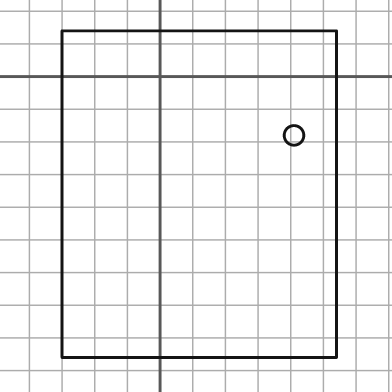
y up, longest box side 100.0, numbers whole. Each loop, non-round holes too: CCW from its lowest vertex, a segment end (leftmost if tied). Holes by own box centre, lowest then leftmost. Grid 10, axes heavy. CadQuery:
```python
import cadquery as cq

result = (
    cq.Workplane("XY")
    .moveTo(-30.0, -86.0)
    .lineTo(54.0, -86.0)
    .lineTo(54.0, 14.0)
    .lineTo(-30.0, 14.0)
    .close()
    .moveTo(41.0, -18.0)
    .circle(3.0)
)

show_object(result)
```